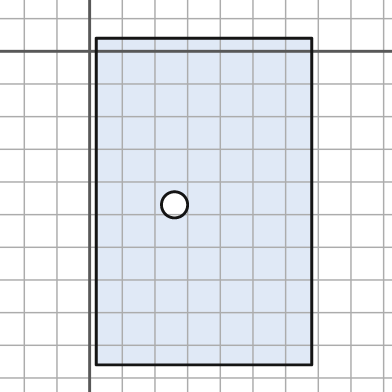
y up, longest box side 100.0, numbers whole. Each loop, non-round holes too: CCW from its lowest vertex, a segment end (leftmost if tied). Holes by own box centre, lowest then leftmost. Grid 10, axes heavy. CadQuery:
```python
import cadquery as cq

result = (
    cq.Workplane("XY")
    .moveTo(2.0, -96.0)
    .lineTo(68.0, -96.0)
    .lineTo(68.0, 4.0)
    .lineTo(2.0, 4.0)
    .close()
    .moveTo(26.0, -47.0)
    .circle(4.0)
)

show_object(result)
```